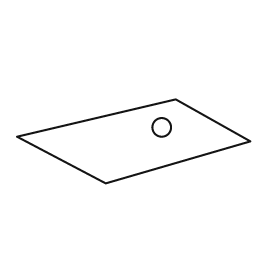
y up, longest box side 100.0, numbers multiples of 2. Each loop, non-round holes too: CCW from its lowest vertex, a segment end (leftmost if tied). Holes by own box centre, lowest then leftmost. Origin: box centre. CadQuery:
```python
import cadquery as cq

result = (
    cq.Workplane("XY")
    .moveTo(-12.0, -18.0)
    .lineTo(50.0, 0.0)
    .lineTo(18.0, 18.0)
    .lineTo(-50.0, 2.0)
    .close()
    .moveTo(12.0, 6.0)
    .circle(4.0)
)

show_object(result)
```